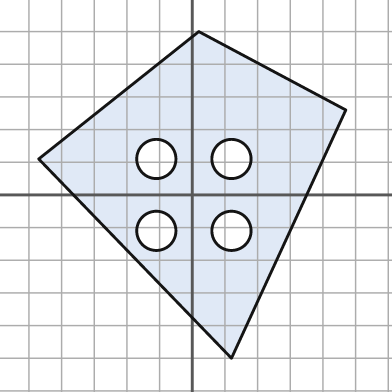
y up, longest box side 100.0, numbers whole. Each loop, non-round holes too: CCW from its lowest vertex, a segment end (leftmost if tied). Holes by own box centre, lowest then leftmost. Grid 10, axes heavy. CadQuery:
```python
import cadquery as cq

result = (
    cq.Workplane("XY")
    .moveTo(12.0, -50.0)
    .lineTo(47.0, 26.0)
    .lineTo(2.0, 50.0)
    .lineTo(-47.0, 11.0)
    .close()
    .moveTo(-11.0, -11.0)
    .circle(6.0)
    .moveTo(12.0, -11.0)
    .circle(6.0)
    .moveTo(-11.0, 11.0)
    .circle(6.0)
    .moveTo(12.0, 11.0)
    .circle(6.0)
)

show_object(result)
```